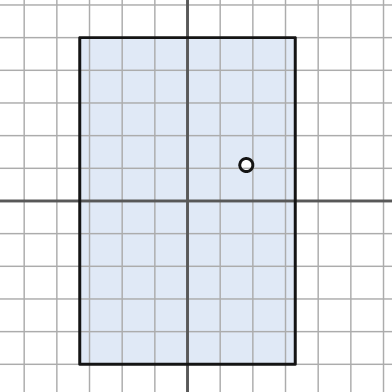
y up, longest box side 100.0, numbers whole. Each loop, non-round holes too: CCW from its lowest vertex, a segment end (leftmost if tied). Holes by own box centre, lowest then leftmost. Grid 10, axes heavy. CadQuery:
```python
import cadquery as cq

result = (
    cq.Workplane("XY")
    .moveTo(-33.0, -50.0)
    .lineTo(33.0, -50.0)
    .lineTo(33.0, 50.0)
    .lineTo(-33.0, 50.0)
    .close()
    .moveTo(18.0, 11.0)
    .circle(2.0)
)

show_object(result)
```